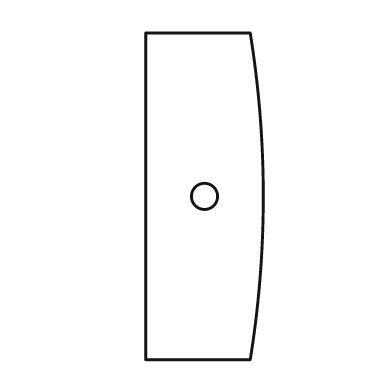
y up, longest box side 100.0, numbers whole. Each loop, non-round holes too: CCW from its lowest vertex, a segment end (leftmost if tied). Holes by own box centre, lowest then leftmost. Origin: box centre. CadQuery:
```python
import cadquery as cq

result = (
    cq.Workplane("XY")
    .moveTo(-18.0, -50.0)
    .lineTo(14.0, -50.0)
    .threePointArc((18.0, 0.0), (14.0, 50.0))
    .lineTo(-18.0, 50.0)
    .close()
    .moveTo(0.0, 0.0)
    .circle(4.0)
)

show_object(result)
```